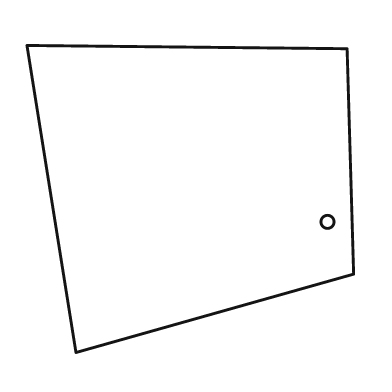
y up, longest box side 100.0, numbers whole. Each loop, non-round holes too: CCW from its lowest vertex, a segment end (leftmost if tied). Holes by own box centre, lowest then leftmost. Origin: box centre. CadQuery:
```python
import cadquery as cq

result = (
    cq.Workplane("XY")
    .moveTo(-35.0, -47.0)
    .lineTo(50.0, -23.0)
    .lineTo(48.0, 46.0)
    .lineTo(-50.0, 47.0)
    .close()
    .moveTo(42.0, -7.0)
    .circle(2.0)
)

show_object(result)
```